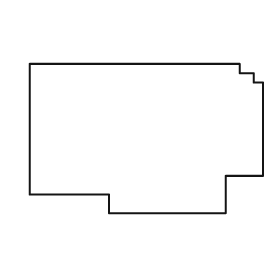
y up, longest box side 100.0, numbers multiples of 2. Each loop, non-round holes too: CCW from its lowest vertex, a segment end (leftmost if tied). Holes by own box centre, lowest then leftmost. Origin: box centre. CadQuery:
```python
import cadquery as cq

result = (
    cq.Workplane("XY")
    .moveTo(-16.0, -32.0)
    .lineTo(34.0, -32.0)
    .lineTo(34.0, -16.0)
    .lineTo(50.0, -16.0)
    .lineTo(50.0, 24.0)
    .lineTo(46.0, 24.0)
    .lineTo(46.0, 28.0)
    .lineTo(40.0, 28.0)
    .lineTo(40.0, 32.0)
    .lineTo(-50.0, 32.0)
    .lineTo(-50.0, -24.0)
    .lineTo(-16.0, -24.0)
    .close()
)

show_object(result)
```